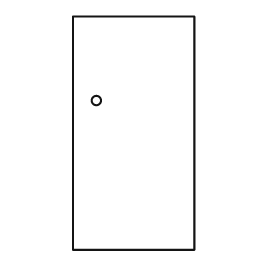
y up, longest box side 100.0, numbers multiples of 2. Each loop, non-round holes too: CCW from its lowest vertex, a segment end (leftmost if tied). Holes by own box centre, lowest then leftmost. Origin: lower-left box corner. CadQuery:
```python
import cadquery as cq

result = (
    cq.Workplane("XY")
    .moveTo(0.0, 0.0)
    .lineTo(52.0, 0.0)
    .lineTo(52.0, 100.0)
    .lineTo(0.0, 100.0)
    .close()
    .moveTo(10.0, 64.0)
    .circle(2.0)
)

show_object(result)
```